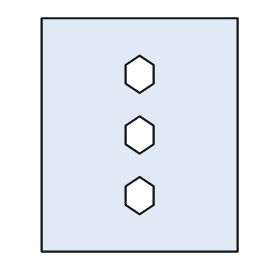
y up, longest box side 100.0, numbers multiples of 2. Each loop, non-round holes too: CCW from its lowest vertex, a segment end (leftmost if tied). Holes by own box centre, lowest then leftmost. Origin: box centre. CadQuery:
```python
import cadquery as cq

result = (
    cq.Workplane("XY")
    .moveTo(-42.0, -50.0)
    .lineTo(42.0, -50.0)
    .lineTo(42.0, 50.0)
    .lineTo(-42.0, 50.0)
    .close()
    .moveTo(0.0, -34.0)
    .lineTo(6.0, -30.0)
    .lineTo(6.0, -22.0)
    .lineTo(0.0, -18.0)
    .lineTo(-6.0, -22.0)
    .lineTo(-6.0, -30.0)
    .close()
    .moveTo(0.0, -8.0)
    .lineTo(6.0, -4.0)
    .lineTo(6.0, 4.0)
    .lineTo(0.0, 8.0)
    .lineTo(-6.0, 4.0)
    .lineTo(-6.0, -4.0)
    .close()
    .moveTo(0.0, 18.0)
    .lineTo(6.0, 22.0)
    .lineTo(6.0, 30.0)
    .lineTo(0.0, 34.0)
    .lineTo(-6.0, 30.0)
    .lineTo(-6.0, 22.0)
    .close()
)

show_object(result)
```